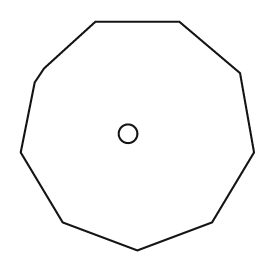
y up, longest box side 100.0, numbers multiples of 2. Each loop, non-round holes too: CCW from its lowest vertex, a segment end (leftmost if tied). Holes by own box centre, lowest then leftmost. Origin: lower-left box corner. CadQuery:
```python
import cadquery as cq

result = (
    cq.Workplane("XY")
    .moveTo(50.0, 0.0)
    .lineTo(82.0, 12.0)
    .lineTo(100.0, 42.0)
    .lineTo(94.0, 76.0)
    .lineTo(68.0, 98.0)
    .lineTo(32.0, 98.0)
    .lineTo(10.0, 78.0)
    .lineTo(6.0, 72.0)
    .lineTo(0.0, 42.0)
    .lineTo(18.0, 12.0)
    .close()
    .moveTo(46.0, 50.0)
    .circle(4.0)
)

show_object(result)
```